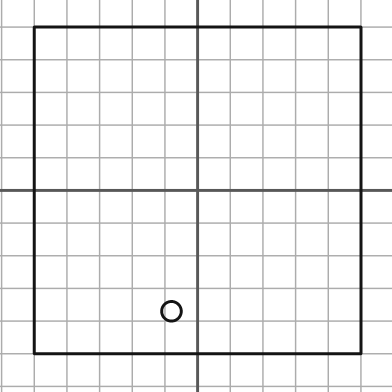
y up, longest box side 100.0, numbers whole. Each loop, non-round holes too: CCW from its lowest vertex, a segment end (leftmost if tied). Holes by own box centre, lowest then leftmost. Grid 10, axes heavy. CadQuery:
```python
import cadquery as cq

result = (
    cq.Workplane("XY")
    .moveTo(-50.0, -50.0)
    .lineTo(50.0, -50.0)
    .lineTo(50.0, 50.0)
    .lineTo(-50.0, 50.0)
    .close()
    .moveTo(-8.0, -37.0)
    .circle(3.0)
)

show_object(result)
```